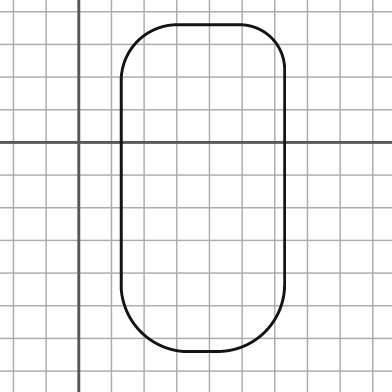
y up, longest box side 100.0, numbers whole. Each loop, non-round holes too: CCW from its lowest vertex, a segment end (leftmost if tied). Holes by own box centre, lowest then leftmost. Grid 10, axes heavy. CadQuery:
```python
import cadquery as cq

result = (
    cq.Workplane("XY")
    .moveTo(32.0, -64.0)
    .lineTo(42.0, -64.0)
    .threePointArc((57.0, -58.0), (63.0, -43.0))
    .lineTo(63.0, 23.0)
    .threePointArc((59.0, 32.0), (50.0, 36.0))
    .lineTo(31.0, 36.0)
    .threePointArc((18.0, 31.0), (13.0, 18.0))
    .lineTo(13.0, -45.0)
    .threePointArc((19.0, -58.0), (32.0, -64.0))
    .close()
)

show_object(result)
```